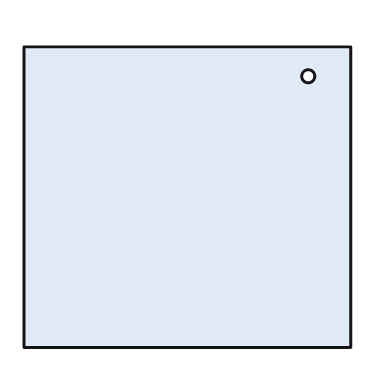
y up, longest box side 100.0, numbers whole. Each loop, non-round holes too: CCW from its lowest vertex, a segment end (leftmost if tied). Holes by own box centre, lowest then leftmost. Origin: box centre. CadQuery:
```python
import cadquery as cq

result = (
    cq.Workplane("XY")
    .moveTo(-50.0, -46.0)
    .lineTo(50.0, -46.0)
    .lineTo(50.0, 46.0)
    .lineTo(-50.0, 46.0)
    .close()
    .moveTo(37.0, 37.0)
    .circle(2.0)
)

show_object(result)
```